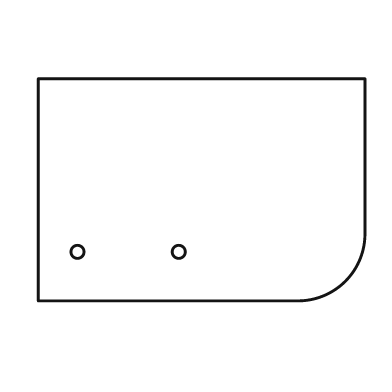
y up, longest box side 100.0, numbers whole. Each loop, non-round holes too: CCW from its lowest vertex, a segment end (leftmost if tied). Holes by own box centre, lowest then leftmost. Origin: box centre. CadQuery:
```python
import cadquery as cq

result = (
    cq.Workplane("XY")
    .moveTo(-50.0, -34.0)
    .lineTo(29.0, -34.0)
    .threePointArc((44.0, -28.0), (50.0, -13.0))
    .lineTo(50.0, 34.0)
    .lineTo(-50.0, 34.0)
    .close()
    .moveTo(-38.0, -19.0)
    .circle(2.0)
    .moveTo(-7.0, -19.0)
    .circle(2.0)
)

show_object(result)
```